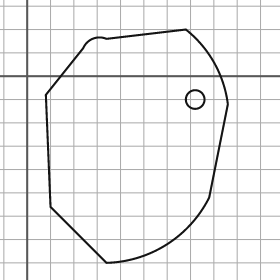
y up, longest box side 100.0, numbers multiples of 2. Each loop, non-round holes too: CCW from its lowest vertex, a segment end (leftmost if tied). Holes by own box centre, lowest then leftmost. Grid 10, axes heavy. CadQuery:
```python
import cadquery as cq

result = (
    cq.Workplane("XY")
    .moveTo(34.0, -80.0)
    .threePointArc((60.0, -72.0), (78.0, -52.0))
    .lineTo(86.0, -12.0)
    .threePointArc((80.0, 6.0), (68.0, 20.0))
    .lineTo(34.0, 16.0)
    .threePointArc((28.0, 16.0), (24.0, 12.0))
    .lineTo(8.0, -8.0)
    .lineTo(10.0, -56.0)
    .close()
    .moveTo(72.0, -10.0)
    .circle(4.0)
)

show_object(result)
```